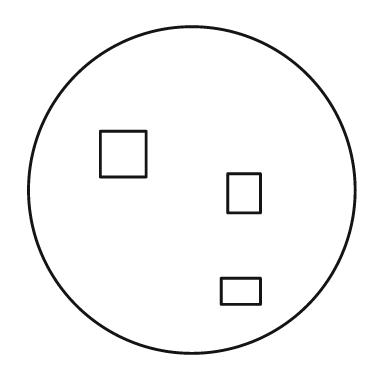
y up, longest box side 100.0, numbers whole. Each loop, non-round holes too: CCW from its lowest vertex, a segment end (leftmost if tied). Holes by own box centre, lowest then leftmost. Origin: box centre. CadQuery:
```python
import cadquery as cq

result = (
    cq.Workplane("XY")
    .moveTo(0.0, 0.0)
    .circle(50.0)
    .moveTo(9.0, -35.0)
    .lineTo(21.0, -35.0)
    .lineTo(21.0, -27.0)
    .lineTo(9.0, -27.0)
    .close()
    .moveTo(11.0, -7.0)
    .lineTo(21.0, -7.0)
    .lineTo(21.0, 5.0)
    .lineTo(11.0, 5.0)
    .close()
    .moveTo(-28.0, 4.0)
    .lineTo(-14.0, 4.0)
    .lineTo(-14.0, 18.0)
    .lineTo(-28.0, 18.0)
    .close()
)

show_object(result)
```